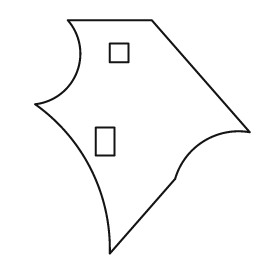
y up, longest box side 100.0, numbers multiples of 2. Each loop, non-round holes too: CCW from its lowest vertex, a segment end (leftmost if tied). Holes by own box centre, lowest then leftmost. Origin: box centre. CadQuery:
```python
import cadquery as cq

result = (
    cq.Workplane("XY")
    .moveTo(-14.0, -50.0)
    .lineTo(14.0, -18.0)
    .threePointArc((26.0, -2.0), (46.0, 2.0))
    .lineTo(4.0, 50.0)
    .lineTo(-32.0, 50.0)
    .threePointArc((-28.0, 28.0), (-46.0, 14.0))
    .threePointArc((-22.0, -14.0), (-14.0, -50.0))
    .close()
    .moveTo(-20.0, -8.0)
    .lineTo(-12.0, -8.0)
    .lineTo(-12.0, 4.0)
    .lineTo(-20.0, 4.0)
    .close()
    .moveTo(-14.0, 32.0)
    .lineTo(-6.0, 32.0)
    .lineTo(-6.0, 40.0)
    .lineTo(-14.0, 40.0)
    .close()
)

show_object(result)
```